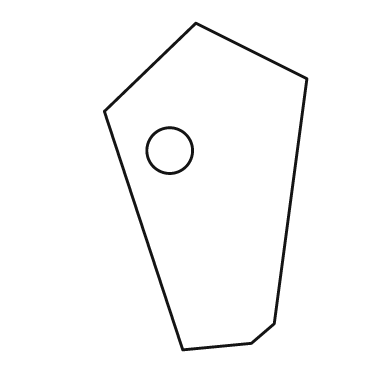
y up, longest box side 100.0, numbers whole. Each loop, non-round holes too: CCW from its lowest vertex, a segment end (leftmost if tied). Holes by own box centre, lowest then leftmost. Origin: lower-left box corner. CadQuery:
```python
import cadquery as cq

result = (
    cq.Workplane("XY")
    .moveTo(24.0, 0.0)
    .lineTo(45.0, 2.0)
    .lineTo(52.0, 8.0)
    .lineTo(62.0, 83.0)
    .lineTo(28.0, 100.0)
    .lineTo(0.0, 73.0)
    .close()
    .moveTo(20.0, 61.0)
    .circle(7.0)
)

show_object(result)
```